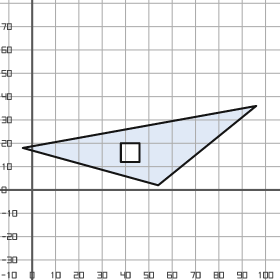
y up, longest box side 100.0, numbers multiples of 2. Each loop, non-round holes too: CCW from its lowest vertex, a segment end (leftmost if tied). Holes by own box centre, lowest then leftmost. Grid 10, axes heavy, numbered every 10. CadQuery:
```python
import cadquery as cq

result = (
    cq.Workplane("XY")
    .moveTo(54.0, 2.0)
    .lineTo(96.0, 36.0)
    .lineTo(-4.0, 18.0)
    .close()
    .moveTo(38.0, 12.0)
    .lineTo(46.0, 12.0)
    .lineTo(46.0, 20.0)
    .lineTo(38.0, 20.0)
    .close()
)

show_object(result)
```